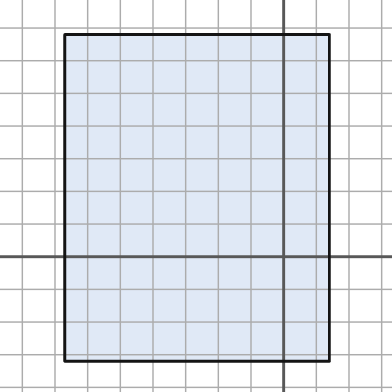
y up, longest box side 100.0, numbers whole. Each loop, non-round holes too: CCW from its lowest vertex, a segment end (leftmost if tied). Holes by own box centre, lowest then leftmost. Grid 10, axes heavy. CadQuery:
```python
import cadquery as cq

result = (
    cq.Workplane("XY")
    .moveTo(-67.0, -32.0)
    .lineTo(14.0, -32.0)
    .lineTo(14.0, 68.0)
    .lineTo(-67.0, 68.0)
    .close()
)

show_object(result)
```